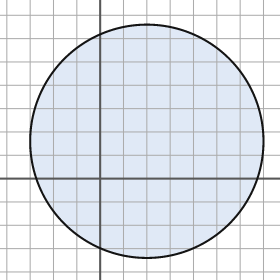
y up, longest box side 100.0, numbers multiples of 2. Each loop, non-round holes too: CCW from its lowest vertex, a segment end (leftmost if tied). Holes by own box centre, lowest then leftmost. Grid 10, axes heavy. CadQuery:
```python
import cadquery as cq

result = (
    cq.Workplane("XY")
    .moveTo(20.0, 16.0)
    .circle(50.0)
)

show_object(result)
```